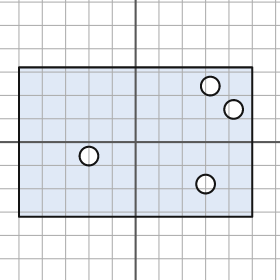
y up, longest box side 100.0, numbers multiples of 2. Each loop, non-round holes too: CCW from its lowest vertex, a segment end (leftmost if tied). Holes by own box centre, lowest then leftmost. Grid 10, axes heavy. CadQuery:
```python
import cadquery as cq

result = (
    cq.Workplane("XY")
    .moveTo(-50.0, -32.0)
    .lineTo(50.0, -32.0)
    .lineTo(50.0, 32.0)
    .lineTo(-50.0, 32.0)
    .close()
    .moveTo(30.0, -18.0)
    .circle(4.0)
    .moveTo(-20.0, -6.0)
    .circle(4.0)
    .moveTo(42.0, 14.0)
    .circle(4.0)
    .moveTo(32.0, 24.0)
    .circle(4.0)
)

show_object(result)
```